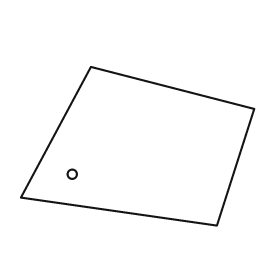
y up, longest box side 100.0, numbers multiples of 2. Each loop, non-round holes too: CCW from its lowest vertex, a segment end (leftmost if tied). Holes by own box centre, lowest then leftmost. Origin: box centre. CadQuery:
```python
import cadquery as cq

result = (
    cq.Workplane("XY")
    .moveTo(34.0, -34.0)
    .lineTo(50.0, 16.0)
    .lineTo(-20.0, 34.0)
    .lineTo(-50.0, -22.0)
    .close()
    .moveTo(-28.0, -12.0)
    .circle(2.0)
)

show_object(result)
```